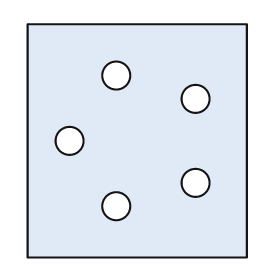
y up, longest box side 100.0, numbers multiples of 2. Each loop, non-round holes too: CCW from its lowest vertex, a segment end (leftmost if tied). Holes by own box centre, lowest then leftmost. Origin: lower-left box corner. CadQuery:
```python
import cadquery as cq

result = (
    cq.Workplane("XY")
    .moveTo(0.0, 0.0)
    .lineTo(94.0, 0.0)
    .lineTo(94.0, 100.0)
    .lineTo(0.0, 100.0)
    .close()
    .moveTo(38.0, 22.0)
    .circle(6.0)
    .moveTo(72.0, 32.0)
    .circle(6.0)
    .moveTo(18.0, 50.0)
    .circle(6.0)
    .moveTo(72.0, 68.0)
    .circle(6.0)
    .moveTo(38.0, 78.0)
    .circle(6.0)
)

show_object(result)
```